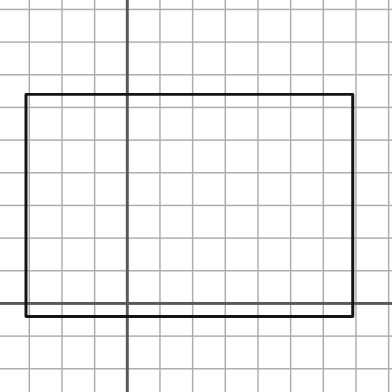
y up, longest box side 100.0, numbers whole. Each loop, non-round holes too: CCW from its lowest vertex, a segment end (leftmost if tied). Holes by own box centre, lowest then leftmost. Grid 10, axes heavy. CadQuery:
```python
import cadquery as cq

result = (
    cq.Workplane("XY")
    .moveTo(-31.0, -4.0)
    .lineTo(69.0, -4.0)
    .lineTo(69.0, 64.0)
    .lineTo(-31.0, 64.0)
    .close()
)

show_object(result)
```